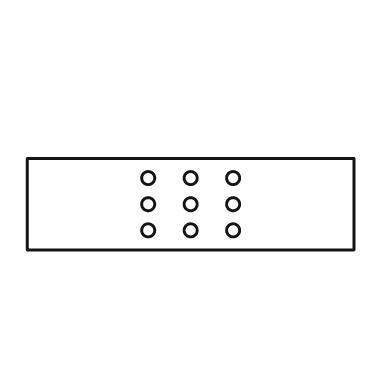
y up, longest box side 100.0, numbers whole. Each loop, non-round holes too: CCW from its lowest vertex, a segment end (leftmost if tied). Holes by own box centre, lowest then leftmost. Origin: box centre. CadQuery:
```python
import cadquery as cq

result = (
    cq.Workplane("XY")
    .moveTo(-50.0, -14.0)
    .lineTo(50.0, -14.0)
    .lineTo(50.0, 14.0)
    .lineTo(-50.0, 14.0)
    .close()
    .moveTo(-13.0, -8.0)
    .circle(2.0)
    .moveTo(0.0, -8.0)
    .circle(2.0)
    .moveTo(13.0, -8.0)
    .circle(2.0)
    .moveTo(-13.0, 0.0)
    .circle(2.0)
    .moveTo(0.0, 0.0)
    .circle(2.0)
    .moveTo(13.0, 0.0)
    .circle(2.0)
    .moveTo(-13.0, 8.0)
    .circle(2.0)
    .moveTo(0.0, 8.0)
    .circle(2.0)
    .moveTo(13.0, 8.0)
    .circle(2.0)
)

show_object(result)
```